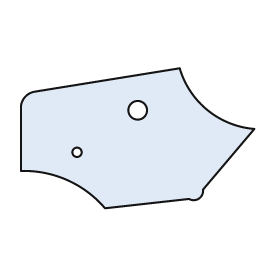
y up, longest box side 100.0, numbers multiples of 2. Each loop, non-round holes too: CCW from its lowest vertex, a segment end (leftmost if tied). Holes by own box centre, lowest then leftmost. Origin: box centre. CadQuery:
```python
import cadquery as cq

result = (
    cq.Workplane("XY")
    .moveTo(-14.0, -30.0)
    .lineTo(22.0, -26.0)
    .threePointArc((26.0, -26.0), (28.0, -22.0))
    .lineTo(50.0, 4.0)
    .threePointArc((30.0, 12.0), (18.0, 30.0))
    .lineTo(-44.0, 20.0)
    .threePointArc((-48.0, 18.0), (-50.0, 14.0))
    .lineTo(-50.0, -14.0)
    .threePointArc((-30.0, -18.0), (-14.0, -30.0))
    .close()
    .moveTo(-26.0, -6.0)
    .circle(2.0)
    .moveTo(0.0, 12.0)
    .circle(4.0)
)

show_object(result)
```